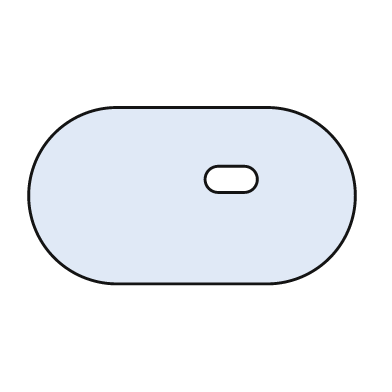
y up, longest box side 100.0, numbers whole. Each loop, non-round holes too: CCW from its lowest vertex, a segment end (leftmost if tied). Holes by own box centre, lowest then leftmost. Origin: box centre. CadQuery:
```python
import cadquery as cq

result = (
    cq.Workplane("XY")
    .moveTo(-23.0, -27.0)
    .lineTo(23.0, -27.0)
    .threePointArc((50.0, 0.0), (23.0, 27.0))
    .lineTo(-23.0, 27.0)
    .threePointArc((-50.0, 0.0), (-23.0, -27.0))
    .close()
    .moveTo(8.0, 1.0)
    .lineTo(16.0, 1.0)
    .threePointArc((20.0, 5.0), (16.0, 9.0))
    .lineTo(8.0, 9.0)
    .threePointArc((4.0, 5.0), (8.0, 1.0))
    .close()
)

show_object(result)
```